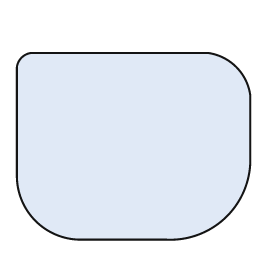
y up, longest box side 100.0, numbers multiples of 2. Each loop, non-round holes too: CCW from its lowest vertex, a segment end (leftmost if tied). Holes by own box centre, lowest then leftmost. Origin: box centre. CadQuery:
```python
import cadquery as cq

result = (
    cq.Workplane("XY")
    .moveTo(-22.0, -40.0)
    .lineTo(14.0, -40.0)
    .threePointArc((40.0, -30.0), (50.0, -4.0))
    .lineTo(50.0, 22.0)
    .threePointArc((44.0, 34.0), (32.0, 40.0))
    .lineTo(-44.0, 40.0)
    .threePointArc((-48.0, 38.0), (-50.0, 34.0))
    .lineTo(-50.0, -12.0)
    .threePointArc((-42.0, -32.0), (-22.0, -40.0))
    .close()
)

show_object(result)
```